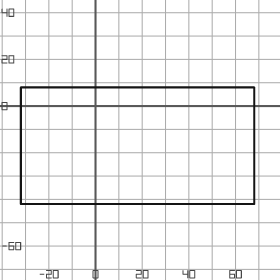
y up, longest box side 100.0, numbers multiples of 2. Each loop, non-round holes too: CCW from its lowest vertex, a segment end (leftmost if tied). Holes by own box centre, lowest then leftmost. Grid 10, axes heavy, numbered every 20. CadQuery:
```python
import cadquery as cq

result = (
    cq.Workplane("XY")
    .moveTo(-32.0, -42.0)
    .lineTo(68.0, -42.0)
    .lineTo(68.0, 8.0)
    .lineTo(-32.0, 8.0)
    .close()
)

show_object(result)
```